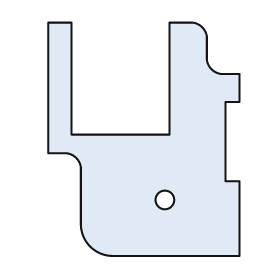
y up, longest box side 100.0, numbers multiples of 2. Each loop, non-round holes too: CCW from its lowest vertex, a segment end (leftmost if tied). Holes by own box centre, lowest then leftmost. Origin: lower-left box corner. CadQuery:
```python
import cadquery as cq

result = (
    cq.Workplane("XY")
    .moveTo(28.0, 0.0)
    .lineTo(82.0, 0.0)
    .lineTo(82.0, 32.0)
    .lineTo(76.0, 32.0)
    .lineTo(76.0, 66.0)
    .lineTo(82.0, 66.0)
    .lineTo(82.0, 78.0)
    .lineTo(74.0, 78.0)
    .threePointArc((70.0, 80.0), (68.0, 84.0))
    .lineTo(68.0, 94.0)
    .threePointArc((66.0, 98.0), (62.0, 100.0))
    .lineTo(52.0, 100.0)
    .lineTo(52.0, 52.0)
    .lineTo(10.0, 52.0)
    .lineTo(10.0, 100.0)
    .lineTo(0.0, 100.0)
    .lineTo(0.0, 44.0)
    .lineTo(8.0, 44.0)
    .threePointArc((12.0, 42.0), (14.0, 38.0))
    .lineTo(14.0, 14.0)
    .threePointArc((18.0, 4.0), (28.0, 0.0))
    .close()
    .moveTo(50.0, 24.0)
    .circle(4.0)
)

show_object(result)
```